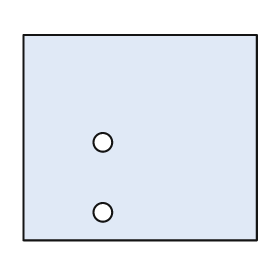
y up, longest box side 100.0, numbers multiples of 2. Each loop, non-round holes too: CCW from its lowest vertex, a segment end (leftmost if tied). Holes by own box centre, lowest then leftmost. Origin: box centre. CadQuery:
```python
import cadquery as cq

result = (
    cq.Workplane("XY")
    .moveTo(-50.0, -44.0)
    .lineTo(50.0, -44.0)
    .lineTo(50.0, 44.0)
    .lineTo(-50.0, 44.0)
    .close()
    .moveTo(-16.0, -32.0)
    .circle(4.0)
    .moveTo(-16.0, -2.0)
    .circle(4.0)
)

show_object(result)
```